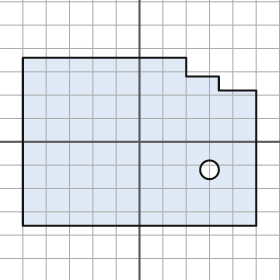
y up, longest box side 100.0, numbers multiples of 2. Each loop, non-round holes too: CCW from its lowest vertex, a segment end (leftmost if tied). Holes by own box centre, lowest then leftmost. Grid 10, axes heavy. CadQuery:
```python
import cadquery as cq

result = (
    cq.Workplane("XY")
    .moveTo(-50.0, -36.0)
    .lineTo(50.0, -36.0)
    .lineTo(50.0, 22.0)
    .lineTo(34.0, 22.0)
    .lineTo(34.0, 28.0)
    .lineTo(20.0, 28.0)
    .lineTo(20.0, 36.0)
    .lineTo(-50.0, 36.0)
    .close()
    .moveTo(30.0, -12.0)
    .circle(4.0)
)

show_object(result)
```